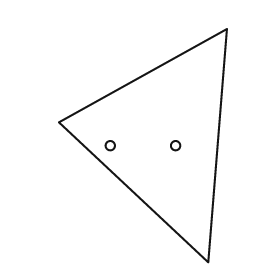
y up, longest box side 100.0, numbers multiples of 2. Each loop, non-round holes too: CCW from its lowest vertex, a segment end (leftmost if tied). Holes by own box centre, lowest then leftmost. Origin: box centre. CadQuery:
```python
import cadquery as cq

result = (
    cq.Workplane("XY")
    .moveTo(28.0, -50.0)
    .lineTo(36.0, 50.0)
    .lineTo(-36.0, 10.0)
    .close()
    .moveTo(-14.0, 0.0)
    .circle(2.0)
    .moveTo(14.0, 0.0)
    .circle(2.0)
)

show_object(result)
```